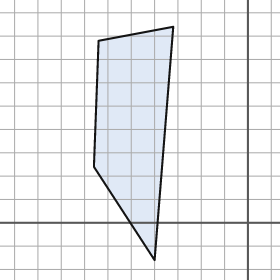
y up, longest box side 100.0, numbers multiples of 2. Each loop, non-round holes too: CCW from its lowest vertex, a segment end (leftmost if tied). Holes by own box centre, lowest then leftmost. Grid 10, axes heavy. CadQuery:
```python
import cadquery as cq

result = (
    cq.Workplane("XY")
    .moveTo(-40.0, -16.0)
    .lineTo(-32.0, 84.0)
    .lineTo(-64.0, 78.0)
    .lineTo(-66.0, 24.0)
    .close()
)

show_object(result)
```